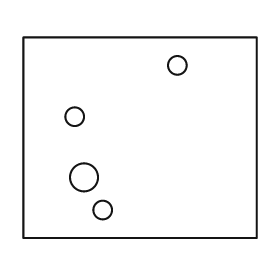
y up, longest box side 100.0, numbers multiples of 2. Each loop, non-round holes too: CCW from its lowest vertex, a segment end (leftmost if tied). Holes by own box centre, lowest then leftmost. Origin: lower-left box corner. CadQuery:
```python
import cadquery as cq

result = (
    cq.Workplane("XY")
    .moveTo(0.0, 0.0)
    .lineTo(100.0, 0.0)
    .lineTo(100.0, 86.0)
    .lineTo(0.0, 86.0)
    .close()
    .moveTo(34.0, 12.0)
    .circle(4.0)
    .moveTo(26.0, 26.0)
    .circle(6.0)
    .moveTo(22.0, 52.0)
    .circle(4.0)
    .moveTo(66.0, 74.0)
    .circle(4.0)
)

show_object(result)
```